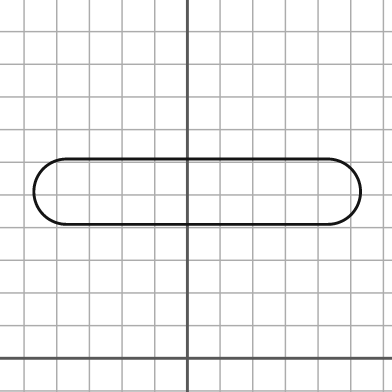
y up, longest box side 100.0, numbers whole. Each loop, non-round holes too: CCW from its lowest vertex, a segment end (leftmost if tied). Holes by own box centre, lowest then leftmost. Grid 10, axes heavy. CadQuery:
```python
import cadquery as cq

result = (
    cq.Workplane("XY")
    .moveTo(-37.0, 41.0)
    .lineTo(43.0, 41.0)
    .threePointArc((53.0, 51.0), (43.0, 61.0))
    .lineTo(-37.0, 61.0)
    .threePointArc((-47.0, 51.0), (-37.0, 41.0))
    .close()
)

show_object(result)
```